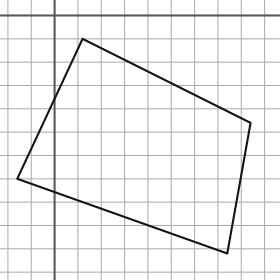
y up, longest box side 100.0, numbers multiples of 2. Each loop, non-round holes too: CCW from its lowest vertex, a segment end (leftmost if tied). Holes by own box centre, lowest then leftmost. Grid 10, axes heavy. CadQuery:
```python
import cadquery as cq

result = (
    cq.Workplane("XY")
    .moveTo(74.0, -102.0)
    .lineTo(84.0, -46.0)
    .lineTo(12.0, -10.0)
    .lineTo(-16.0, -70.0)
    .close()
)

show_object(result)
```